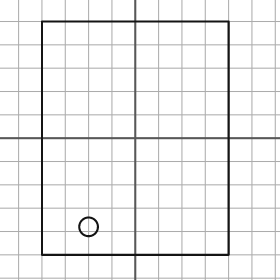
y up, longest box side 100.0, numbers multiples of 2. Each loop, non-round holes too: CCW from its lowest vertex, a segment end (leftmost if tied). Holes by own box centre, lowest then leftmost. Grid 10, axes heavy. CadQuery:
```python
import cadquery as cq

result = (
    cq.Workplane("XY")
    .moveTo(-40.0, -50.0)
    .lineTo(40.0, -50.0)
    .lineTo(40.0, 50.0)
    .lineTo(-40.0, 50.0)
    .close()
    .moveTo(-20.0, -38.0)
    .circle(4.0)
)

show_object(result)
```